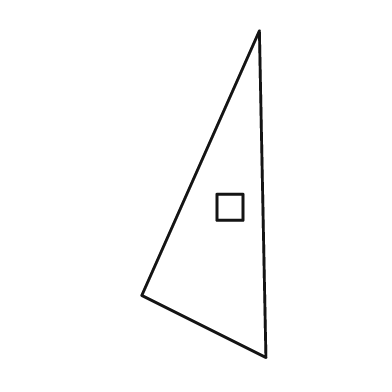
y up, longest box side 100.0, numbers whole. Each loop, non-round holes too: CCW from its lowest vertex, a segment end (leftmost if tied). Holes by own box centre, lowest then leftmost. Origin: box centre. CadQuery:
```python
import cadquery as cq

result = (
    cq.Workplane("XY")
    .moveTo(19.0, -50.0)
    .lineTo(17.0, 50.0)
    .lineTo(-19.0, -31.0)
    .close()
    .moveTo(4.0, -8.0)
    .lineTo(12.0, -8.0)
    .lineTo(12.0, 0.0)
    .lineTo(4.0, 0.0)
    .close()
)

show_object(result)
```